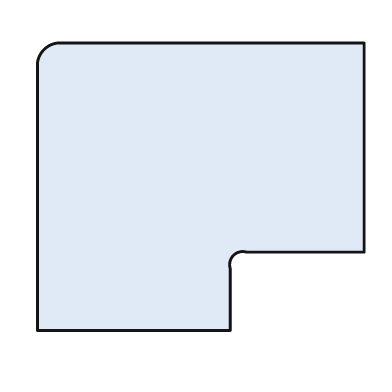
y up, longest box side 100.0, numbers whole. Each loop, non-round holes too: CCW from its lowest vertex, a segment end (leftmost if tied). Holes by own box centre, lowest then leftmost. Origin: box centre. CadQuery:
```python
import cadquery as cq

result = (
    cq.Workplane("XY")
    .moveTo(-50.0, -44.0)
    .lineTo(9.0, -44.0)
    .lineTo(9.0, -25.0)
    .threePointArc((10.0, -21.0), (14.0, -20.0))
    .lineTo(50.0, -20.0)
    .lineTo(50.0, 44.0)
    .lineTo(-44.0, 44.0)
    .threePointArc((-48.0, 42.0), (-50.0, 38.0))
    .close()
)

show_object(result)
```